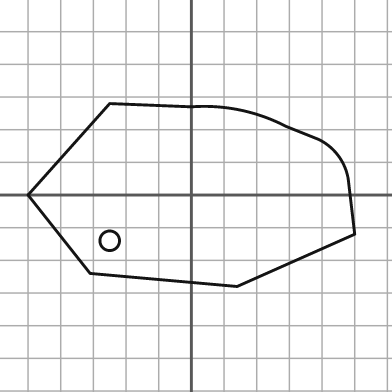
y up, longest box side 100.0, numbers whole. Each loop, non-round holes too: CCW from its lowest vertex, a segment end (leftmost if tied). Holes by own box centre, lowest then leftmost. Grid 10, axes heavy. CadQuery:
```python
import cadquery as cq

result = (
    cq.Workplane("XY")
    .moveTo(14.0, -28.0)
    .lineTo(50.0, -12.0)
    .lineTo(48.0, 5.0)
    .threePointArc((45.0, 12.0), (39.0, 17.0))
    .lineTo(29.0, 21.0)
    .threePointArc((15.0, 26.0), (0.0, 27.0))
    .lineTo(-25.0, 28.0)
    .lineTo(-50.0, 0.0)
    .lineTo(-31.0, -24.0)
    .close()
    .moveTo(-25.0, -14.0)
    .circle(3.0)
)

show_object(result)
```